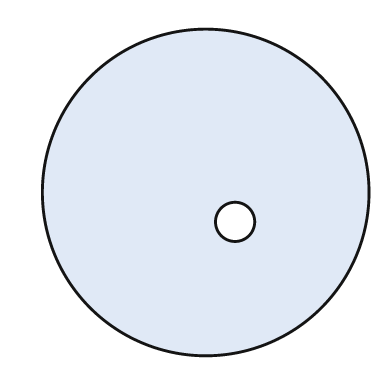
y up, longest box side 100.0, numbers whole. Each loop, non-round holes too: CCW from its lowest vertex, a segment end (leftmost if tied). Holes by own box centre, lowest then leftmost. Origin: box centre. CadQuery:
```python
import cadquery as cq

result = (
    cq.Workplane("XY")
    .moveTo(0.0, 0.0)
    .circle(50.0)
    .moveTo(9.0, -9.0)
    .circle(6.0)
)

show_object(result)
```